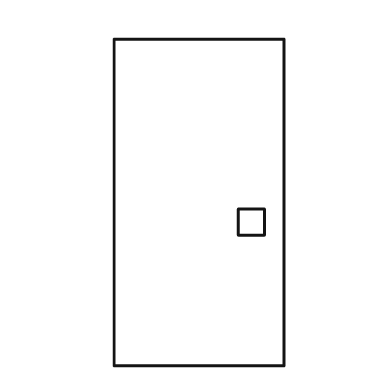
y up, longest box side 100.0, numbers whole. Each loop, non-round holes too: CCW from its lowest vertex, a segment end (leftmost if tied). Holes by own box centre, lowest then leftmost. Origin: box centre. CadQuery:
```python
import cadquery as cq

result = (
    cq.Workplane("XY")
    .moveTo(-26.0, -50.0)
    .lineTo(26.0, -50.0)
    .lineTo(26.0, 50.0)
    .lineTo(-26.0, 50.0)
    .close()
    .moveTo(12.0, -10.0)
    .lineTo(20.0, -10.0)
    .lineTo(20.0, -2.0)
    .lineTo(12.0, -2.0)
    .close()
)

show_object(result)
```